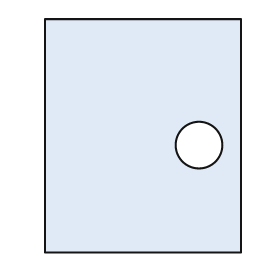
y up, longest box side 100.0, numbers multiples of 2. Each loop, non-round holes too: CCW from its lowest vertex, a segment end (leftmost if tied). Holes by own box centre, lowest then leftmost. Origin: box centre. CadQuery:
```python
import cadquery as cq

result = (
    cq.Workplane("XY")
    .moveTo(-42.0, -50.0)
    .lineTo(42.0, -50.0)
    .lineTo(42.0, 50.0)
    .lineTo(-42.0, 50.0)
    .close()
    .moveTo(24.0, -4.0)
    .circle(10.0)
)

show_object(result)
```